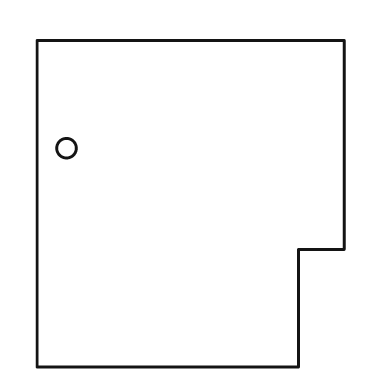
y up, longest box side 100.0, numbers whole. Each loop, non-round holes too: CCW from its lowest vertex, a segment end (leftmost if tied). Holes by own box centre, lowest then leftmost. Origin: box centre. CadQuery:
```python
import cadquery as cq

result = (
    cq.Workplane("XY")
    .moveTo(-47.0, -50.0)
    .lineTo(33.0, -50.0)
    .lineTo(33.0, -14.0)
    .lineTo(47.0, -14.0)
    .lineTo(47.0, 50.0)
    .lineTo(-47.0, 50.0)
    .close()
    .moveTo(-38.0, 17.0)
    .circle(3.0)
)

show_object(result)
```